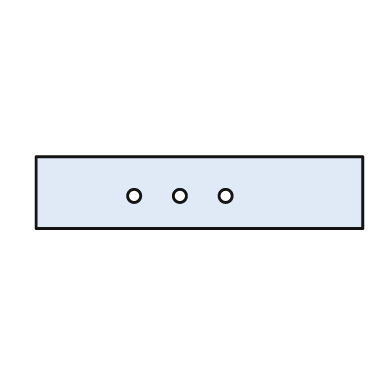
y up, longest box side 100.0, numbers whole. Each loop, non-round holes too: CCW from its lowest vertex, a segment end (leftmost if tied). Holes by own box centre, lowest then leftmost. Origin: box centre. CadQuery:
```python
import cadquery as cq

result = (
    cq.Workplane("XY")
    .moveTo(-50.0, -11.0)
    .lineTo(50.0, -11.0)
    .lineTo(50.0, 11.0)
    .lineTo(-50.0, 11.0)
    .close()
    .moveTo(-20.0, -1.0)
    .circle(2.0)
    .moveTo(-6.0, -1.0)
    .circle(2.0)
    .moveTo(8.0, -1.0)
    .circle(2.0)
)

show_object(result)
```